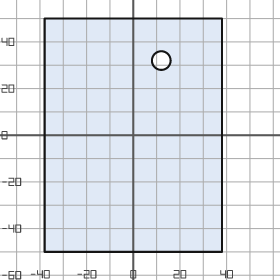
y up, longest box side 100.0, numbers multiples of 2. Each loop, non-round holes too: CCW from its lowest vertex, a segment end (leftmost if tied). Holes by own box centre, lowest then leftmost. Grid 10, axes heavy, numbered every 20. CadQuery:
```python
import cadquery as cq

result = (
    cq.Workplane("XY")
    .moveTo(-38.0, -50.0)
    .lineTo(38.0, -50.0)
    .lineTo(38.0, 50.0)
    .lineTo(-38.0, 50.0)
    .close()
    .moveTo(12.0, 32.0)
    .circle(4.0)
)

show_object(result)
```